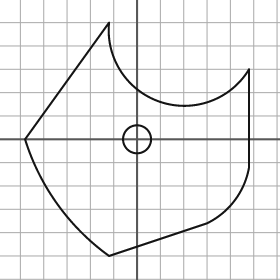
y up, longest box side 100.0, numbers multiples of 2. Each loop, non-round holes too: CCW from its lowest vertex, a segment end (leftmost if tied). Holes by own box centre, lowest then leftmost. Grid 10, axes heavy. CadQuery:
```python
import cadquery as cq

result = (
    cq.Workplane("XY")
    .moveTo(-12.0, -50.0)
    .lineTo(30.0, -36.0)
    .threePointArc((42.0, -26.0), (48.0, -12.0))
    .lineTo(48.0, 30.0)
    .threePointArc((10.0, 16.0), (-12.0, 50.0))
    .lineTo(-48.0, 0.0)
    .threePointArc((-34.0, -28.0), (-12.0, -50.0))
    .close()
    .moveTo(0.0, 0.0)
    .circle(6.0)
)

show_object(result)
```